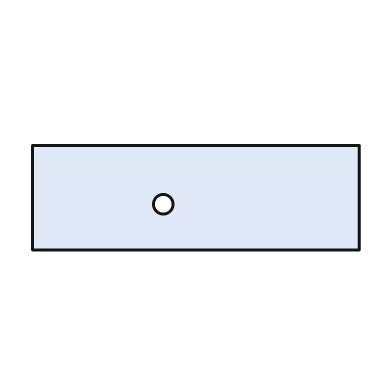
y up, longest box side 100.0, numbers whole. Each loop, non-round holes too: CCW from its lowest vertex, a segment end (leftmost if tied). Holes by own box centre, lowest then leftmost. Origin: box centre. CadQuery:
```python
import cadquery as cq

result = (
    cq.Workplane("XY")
    .moveTo(-50.0, -16.0)
    .lineTo(50.0, -16.0)
    .lineTo(50.0, 16.0)
    .lineTo(-50.0, 16.0)
    .close()
    .moveTo(-10.0, -2.0)
    .circle(3.0)
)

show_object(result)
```